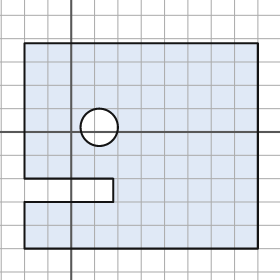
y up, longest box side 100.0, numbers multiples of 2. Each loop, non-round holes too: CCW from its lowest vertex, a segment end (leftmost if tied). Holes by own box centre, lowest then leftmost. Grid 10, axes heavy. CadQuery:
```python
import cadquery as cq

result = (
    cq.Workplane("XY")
    .moveTo(-20.0, -50.0)
    .lineTo(80.0, -50.0)
    .lineTo(80.0, 38.0)
    .lineTo(-20.0, 38.0)
    .lineTo(-20.0, -20.0)
    .lineTo(18.0, -20.0)
    .lineTo(18.0, -30.0)
    .lineTo(-20.0, -30.0)
    .close()
    .moveTo(12.0, 2.0)
    .circle(8.0)
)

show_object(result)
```